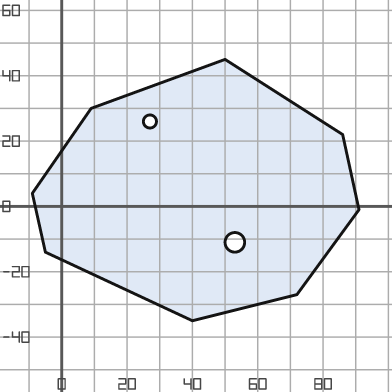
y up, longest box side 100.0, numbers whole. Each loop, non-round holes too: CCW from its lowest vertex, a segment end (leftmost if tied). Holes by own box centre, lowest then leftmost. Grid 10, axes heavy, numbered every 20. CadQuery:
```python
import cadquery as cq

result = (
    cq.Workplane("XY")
    .moveTo(40.0, -35.0)
    .lineTo(72.0, -27.0)
    .lineTo(91.0, -1.0)
    .lineTo(86.0, 22.0)
    .lineTo(50.0, 45.0)
    .lineTo(9.0, 30.0)
    .lineTo(-9.0, 4.0)
    .lineTo(-5.0, -14.0)
    .close()
    .moveTo(53.0, -11.0)
    .circle(3.0)
    .moveTo(27.0, 26.0)
    .circle(2.0)
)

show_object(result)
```